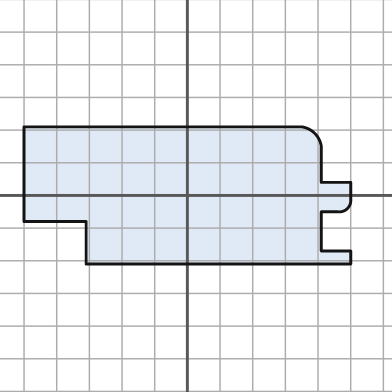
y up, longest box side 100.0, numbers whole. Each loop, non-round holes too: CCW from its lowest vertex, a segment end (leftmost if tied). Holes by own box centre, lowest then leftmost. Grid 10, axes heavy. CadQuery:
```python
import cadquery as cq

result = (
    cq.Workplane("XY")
    .moveTo(-31.0, -21.0)
    .lineTo(50.0, -21.0)
    .lineTo(50.0, -17.0)
    .lineTo(41.0, -17.0)
    .lineTo(41.0, -5.0)
    .lineTo(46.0, -5.0)
    .threePointArc((49.0, -4.0), (50.0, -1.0))
    .lineTo(50.0, 4.0)
    .lineTo(41.0, 4.0)
    .lineTo(41.0, 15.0)
    .threePointArc((39.0, 19.0), (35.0, 21.0))
    .lineTo(-50.0, 21.0)
    .lineTo(-50.0, -8.0)
    .lineTo(-31.0, -8.0)
    .close()
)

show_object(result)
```